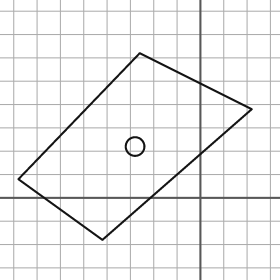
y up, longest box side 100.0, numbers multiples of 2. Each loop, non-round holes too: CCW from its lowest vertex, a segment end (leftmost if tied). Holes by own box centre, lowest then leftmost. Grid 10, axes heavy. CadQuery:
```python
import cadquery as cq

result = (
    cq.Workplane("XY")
    .moveTo(-42.0, -18.0)
    .lineTo(22.0, 38.0)
    .lineTo(-26.0, 62.0)
    .lineTo(-78.0, 8.0)
    .close()
    .moveTo(-28.0, 22.0)
    .circle(4.0)
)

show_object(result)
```